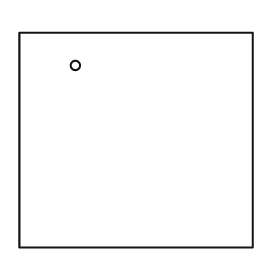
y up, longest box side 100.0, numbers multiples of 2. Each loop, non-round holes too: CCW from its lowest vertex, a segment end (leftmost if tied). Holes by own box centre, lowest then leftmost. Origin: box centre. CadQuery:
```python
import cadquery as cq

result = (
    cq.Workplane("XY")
    .moveTo(-50.0, -46.0)
    .lineTo(50.0, -46.0)
    .lineTo(50.0, 46.0)
    .lineTo(-50.0, 46.0)
    .close()
    .moveTo(-26.0, 32.0)
    .circle(2.0)
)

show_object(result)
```